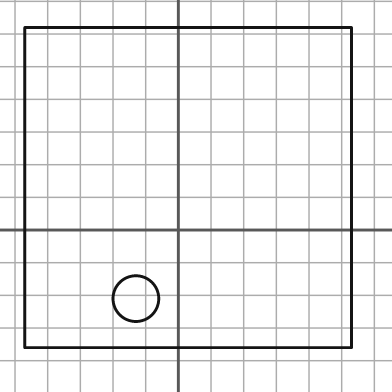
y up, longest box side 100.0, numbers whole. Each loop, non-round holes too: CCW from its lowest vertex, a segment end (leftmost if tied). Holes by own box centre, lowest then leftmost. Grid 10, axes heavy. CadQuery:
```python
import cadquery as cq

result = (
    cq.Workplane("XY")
    .moveTo(-47.0, -36.0)
    .lineTo(53.0, -36.0)
    .lineTo(53.0, 62.0)
    .lineTo(-47.0, 62.0)
    .close()
    .moveTo(-13.0, -21.0)
    .circle(7.0)
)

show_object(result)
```